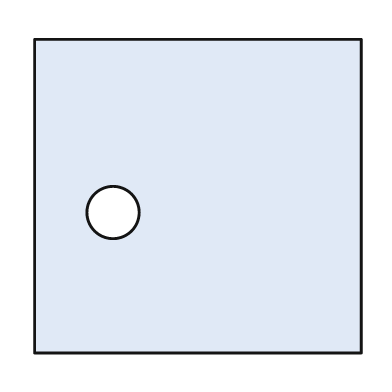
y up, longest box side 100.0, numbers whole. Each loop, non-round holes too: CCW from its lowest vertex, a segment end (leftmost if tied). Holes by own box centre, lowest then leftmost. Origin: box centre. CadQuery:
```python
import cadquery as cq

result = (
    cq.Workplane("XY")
    .moveTo(-50.0, -48.0)
    .lineTo(50.0, -48.0)
    .lineTo(50.0, 48.0)
    .lineTo(-50.0, 48.0)
    .close()
    .moveTo(-26.0, -5.0)
    .circle(8.0)
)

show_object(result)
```